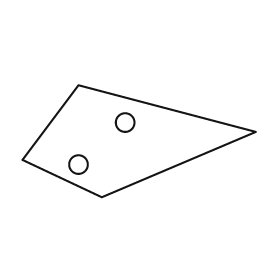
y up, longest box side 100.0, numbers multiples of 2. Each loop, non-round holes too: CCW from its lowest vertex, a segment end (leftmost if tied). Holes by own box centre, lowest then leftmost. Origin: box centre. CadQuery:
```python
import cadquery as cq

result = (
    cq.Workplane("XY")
    .moveTo(-16.0, -24.0)
    .lineTo(50.0, 4.0)
    .lineTo(-26.0, 24.0)
    .lineTo(-50.0, -8.0)
    .close()
    .moveTo(-26.0, -10.0)
    .circle(4.0)
    .moveTo(-6.0, 8.0)
    .circle(4.0)
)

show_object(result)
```